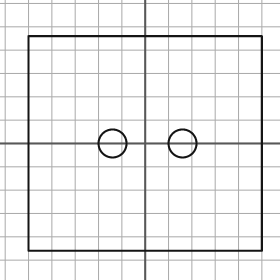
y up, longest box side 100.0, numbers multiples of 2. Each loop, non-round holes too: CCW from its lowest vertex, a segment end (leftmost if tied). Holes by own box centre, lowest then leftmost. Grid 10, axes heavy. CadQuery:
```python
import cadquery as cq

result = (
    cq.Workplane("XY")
    .moveTo(-50.0, -46.0)
    .lineTo(50.0, -46.0)
    .lineTo(50.0, 46.0)
    .lineTo(-50.0, 46.0)
    .close()
    .moveTo(-14.0, 0.0)
    .circle(6.0)
    .moveTo(16.0, 0.0)
    .circle(6.0)
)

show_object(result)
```